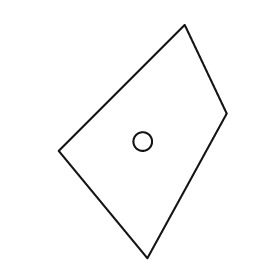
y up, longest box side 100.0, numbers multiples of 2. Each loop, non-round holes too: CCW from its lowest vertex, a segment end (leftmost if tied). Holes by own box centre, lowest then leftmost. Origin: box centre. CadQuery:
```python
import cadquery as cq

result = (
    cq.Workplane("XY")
    .moveTo(2.0, -50.0)
    .lineTo(36.0, 12.0)
    .lineTo(18.0, 50.0)
    .lineTo(-36.0, -4.0)
    .close()
    .moveTo(0.0, 0.0)
    .circle(4.0)
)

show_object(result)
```